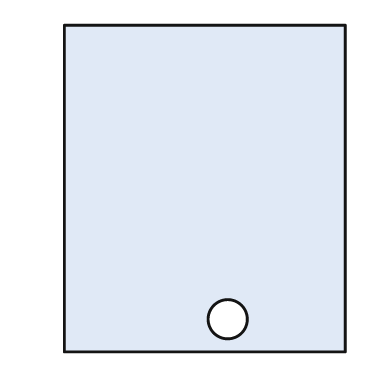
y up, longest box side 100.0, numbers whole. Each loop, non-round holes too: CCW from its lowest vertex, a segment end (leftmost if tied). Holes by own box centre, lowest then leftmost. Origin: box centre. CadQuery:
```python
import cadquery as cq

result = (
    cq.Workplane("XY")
    .moveTo(-43.0, -50.0)
    .lineTo(43.0, -50.0)
    .lineTo(43.0, 50.0)
    .lineTo(-43.0, 50.0)
    .close()
    .moveTo(7.0, -40.0)
    .circle(6.0)
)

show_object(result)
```